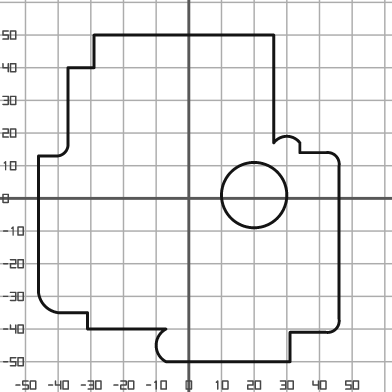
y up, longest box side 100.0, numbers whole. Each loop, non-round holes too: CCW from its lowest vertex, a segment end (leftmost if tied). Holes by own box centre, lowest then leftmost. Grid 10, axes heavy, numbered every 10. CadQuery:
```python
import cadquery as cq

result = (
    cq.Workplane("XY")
    .moveTo(-7.0, -50.0)
    .lineTo(31.0, -50.0)
    .lineTo(31.0, -41.0)
    .lineTo(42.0, -41.0)
    .threePointArc((45.0, -40.0), (46.0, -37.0))
    .lineTo(46.0, 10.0)
    .threePointArc((45.0, 13.0), (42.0, 14.0))
    .lineTo(34.0, 14.0)
    .lineTo(34.0, 17.0)
    .threePointArc((30.0, 19.0), (26.0, 17.0))
    .lineTo(26.0, 50.0)
    .lineTo(-29.0, 50.0)
    .lineTo(-29.0, 40.0)
    .lineTo(-37.0, 40.0)
    .lineTo(-37.0, 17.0)
    .threePointArc((-38.0, 14.0), (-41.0, 13.0))
    .lineTo(-46.0, 13.0)
    .lineTo(-46.0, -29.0)
    .threePointArc((-44.0, -33.0), (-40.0, -35.0))
    .lineTo(-31.0, -35.0)
    .lineTo(-31.0, -40.0)
    .lineTo(-7.0, -40.0)
    .threePointArc((-10.0, -45.0), (-7.0, -50.0))
    .close()
    .moveTo(20.0, 1.0)
    .circle(10.0)
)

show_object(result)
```